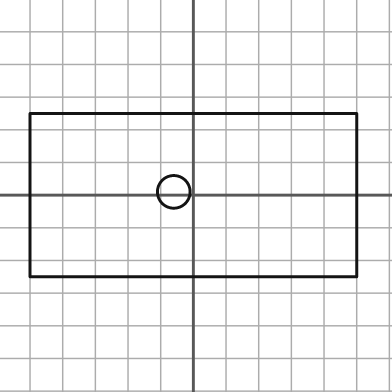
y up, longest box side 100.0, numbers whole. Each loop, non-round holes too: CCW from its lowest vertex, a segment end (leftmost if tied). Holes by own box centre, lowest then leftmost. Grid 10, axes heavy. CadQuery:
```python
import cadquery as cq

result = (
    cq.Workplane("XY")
    .moveTo(-50.0, -25.0)
    .lineTo(50.0, -25.0)
    .lineTo(50.0, 25.0)
    .lineTo(-50.0, 25.0)
    .close()
    .moveTo(-6.0, 1.0)
    .circle(5.0)
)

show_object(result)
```